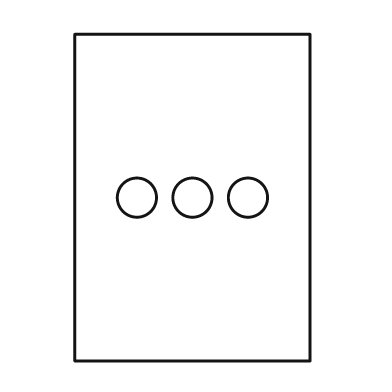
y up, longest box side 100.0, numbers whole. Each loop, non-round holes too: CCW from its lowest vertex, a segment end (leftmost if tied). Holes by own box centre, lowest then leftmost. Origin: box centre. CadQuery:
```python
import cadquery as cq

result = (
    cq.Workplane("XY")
    .moveTo(-36.0, -50.0)
    .lineTo(36.0, -50.0)
    .lineTo(36.0, 50.0)
    .lineTo(-36.0, 50.0)
    .close()
    .moveTo(-17.0, 0.0)
    .circle(6.0)
    .moveTo(0.0, 0.0)
    .circle(6.0)
    .moveTo(17.0, 0.0)
    .circle(6.0)
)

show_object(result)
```